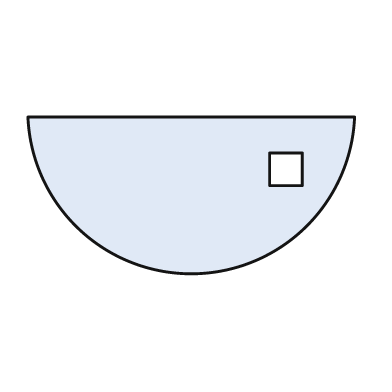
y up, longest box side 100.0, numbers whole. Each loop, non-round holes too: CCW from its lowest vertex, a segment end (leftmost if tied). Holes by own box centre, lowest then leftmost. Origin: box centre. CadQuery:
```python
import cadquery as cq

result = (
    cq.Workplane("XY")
    .moveTo(-50.0, 24.0)
    .threePointArc((0.0, -24.0), (50.0, 24.0))
    .close()
    .moveTo(24.0, 3.0)
    .lineTo(34.0, 3.0)
    .lineTo(34.0, 13.0)
    .lineTo(24.0, 13.0)
    .close()
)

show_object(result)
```